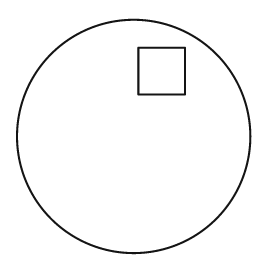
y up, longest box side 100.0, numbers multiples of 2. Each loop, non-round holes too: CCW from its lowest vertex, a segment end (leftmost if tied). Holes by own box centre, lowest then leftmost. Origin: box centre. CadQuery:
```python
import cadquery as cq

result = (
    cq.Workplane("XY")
    .moveTo(0.0, 0.0)
    .circle(50.0)
    .moveTo(2.0, 18.0)
    .lineTo(22.0, 18.0)
    .lineTo(22.0, 38.0)
    .lineTo(2.0, 38.0)
    .close()
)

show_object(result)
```